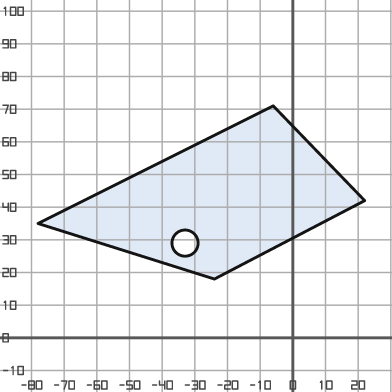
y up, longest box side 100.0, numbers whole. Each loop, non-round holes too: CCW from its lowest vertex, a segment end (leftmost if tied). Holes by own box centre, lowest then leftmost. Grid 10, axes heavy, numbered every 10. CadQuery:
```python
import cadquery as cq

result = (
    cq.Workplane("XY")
    .moveTo(-24.0, 18.0)
    .lineTo(22.0, 42.0)
    .lineTo(-6.0, 71.0)
    .lineTo(-78.0, 35.0)
    .close()
    .moveTo(-33.0, 29.0)
    .circle(4.0)
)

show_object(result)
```